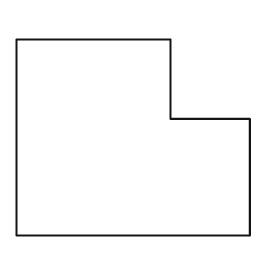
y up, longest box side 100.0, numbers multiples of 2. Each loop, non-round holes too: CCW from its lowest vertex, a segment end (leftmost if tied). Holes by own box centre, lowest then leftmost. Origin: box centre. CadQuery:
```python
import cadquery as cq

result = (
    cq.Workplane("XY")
    .moveTo(-50.0, -42.0)
    .lineTo(50.0, -42.0)
    .lineTo(50.0, 8.0)
    .lineTo(16.0, 8.0)
    .lineTo(16.0, 42.0)
    .lineTo(-50.0, 42.0)
    .close()
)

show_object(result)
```